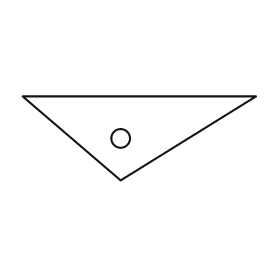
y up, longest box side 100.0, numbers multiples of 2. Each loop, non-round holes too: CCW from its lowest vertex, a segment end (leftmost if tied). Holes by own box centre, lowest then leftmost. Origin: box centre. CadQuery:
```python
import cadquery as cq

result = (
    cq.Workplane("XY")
    .moveTo(-8.0, -18.0)
    .lineTo(50.0, 18.0)
    .lineTo(-50.0, 18.0)
    .close()
    .moveTo(-8.0, 0.0)
    .circle(4.0)
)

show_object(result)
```